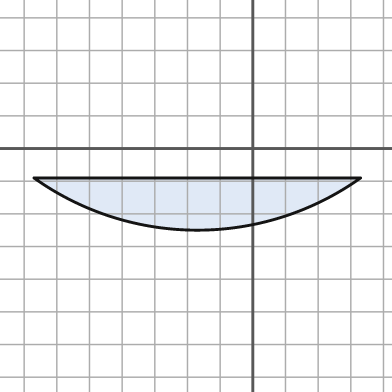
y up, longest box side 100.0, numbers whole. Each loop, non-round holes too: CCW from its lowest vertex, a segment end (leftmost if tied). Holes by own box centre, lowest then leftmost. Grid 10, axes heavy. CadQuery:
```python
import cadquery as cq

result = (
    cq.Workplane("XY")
    .moveTo(-67.0, -9.0)
    .threePointArc((-17.0, -25.0), (33.0, -9.0))
    .close()
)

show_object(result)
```